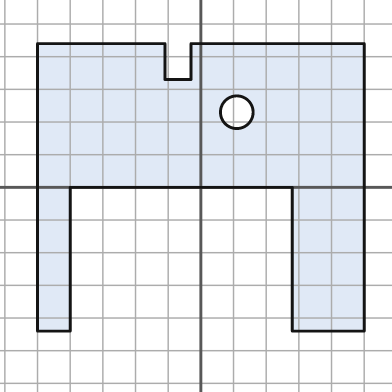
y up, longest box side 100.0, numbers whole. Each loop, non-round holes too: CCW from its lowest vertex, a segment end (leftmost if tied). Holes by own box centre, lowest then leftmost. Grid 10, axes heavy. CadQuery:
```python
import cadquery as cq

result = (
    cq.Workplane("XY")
    .moveTo(-50.0, -44.0)
    .lineTo(-40.0, -44.0)
    .lineTo(-40.0, 0.0)
    .lineTo(28.0, 0.0)
    .lineTo(28.0, -44.0)
    .lineTo(50.0, -44.0)
    .lineTo(50.0, 44.0)
    .lineTo(-3.0, 44.0)
    .lineTo(-3.0, 33.0)
    .lineTo(-11.0, 33.0)
    .lineTo(-11.0, 44.0)
    .lineTo(-50.0, 44.0)
    .close()
    .moveTo(11.0, 23.0)
    .circle(5.0)
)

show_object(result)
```